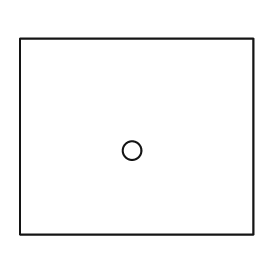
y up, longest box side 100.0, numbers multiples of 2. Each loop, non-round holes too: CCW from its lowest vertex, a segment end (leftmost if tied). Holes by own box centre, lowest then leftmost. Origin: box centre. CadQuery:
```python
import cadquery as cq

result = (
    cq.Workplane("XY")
    .moveTo(-50.0, -42.0)
    .lineTo(50.0, -42.0)
    .lineTo(50.0, 42.0)
    .lineTo(-50.0, 42.0)
    .close()
    .moveTo(-2.0, -6.0)
    .circle(4.0)
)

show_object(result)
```